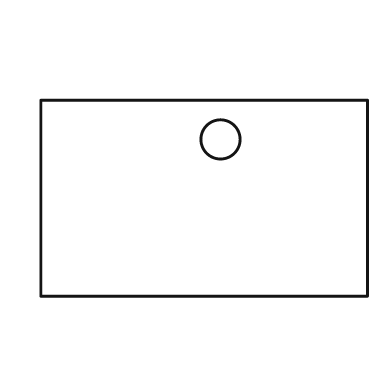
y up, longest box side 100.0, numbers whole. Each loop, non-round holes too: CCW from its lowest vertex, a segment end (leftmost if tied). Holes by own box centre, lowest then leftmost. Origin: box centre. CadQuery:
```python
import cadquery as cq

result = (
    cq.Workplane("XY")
    .moveTo(-50.0, -30.0)
    .lineTo(50.0, -30.0)
    .lineTo(50.0, 30.0)
    .lineTo(-50.0, 30.0)
    .close()
    .moveTo(5.0, 18.0)
    .circle(6.0)
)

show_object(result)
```